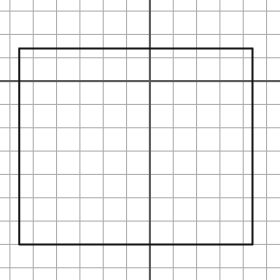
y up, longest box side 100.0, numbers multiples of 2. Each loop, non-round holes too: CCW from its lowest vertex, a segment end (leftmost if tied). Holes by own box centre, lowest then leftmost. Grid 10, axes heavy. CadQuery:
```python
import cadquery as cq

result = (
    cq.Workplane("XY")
    .moveTo(-56.0, -70.0)
    .lineTo(44.0, -70.0)
    .lineTo(44.0, 14.0)
    .lineTo(-56.0, 14.0)
    .close()
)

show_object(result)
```